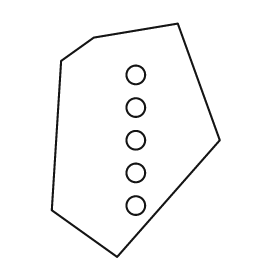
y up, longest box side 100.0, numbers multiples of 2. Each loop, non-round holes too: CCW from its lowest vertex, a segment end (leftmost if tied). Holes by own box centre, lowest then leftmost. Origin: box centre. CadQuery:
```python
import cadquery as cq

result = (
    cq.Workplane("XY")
    .moveTo(-8.0, -50.0)
    .lineTo(36.0, 0.0)
    .lineTo(18.0, 50.0)
    .lineTo(-18.0, 44.0)
    .lineTo(-32.0, 34.0)
    .lineTo(-36.0, -30.0)
    .close()
    .moveTo(0.0, -28.0)
    .circle(4.0)
    .moveTo(0.0, -14.0)
    .circle(4.0)
    .moveTo(0.0, 0.0)
    .circle(4.0)
    .moveTo(0.0, 14.0)
    .circle(4.0)
    .moveTo(0.0, 28.0)
    .circle(4.0)
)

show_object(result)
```